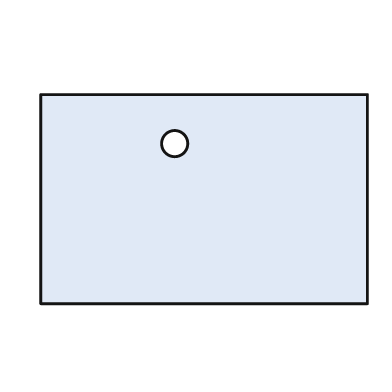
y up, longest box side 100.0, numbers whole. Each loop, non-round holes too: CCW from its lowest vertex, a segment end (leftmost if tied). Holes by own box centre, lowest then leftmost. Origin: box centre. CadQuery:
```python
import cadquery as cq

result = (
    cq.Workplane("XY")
    .moveTo(-50.0, -32.0)
    .lineTo(50.0, -32.0)
    .lineTo(50.0, 32.0)
    .lineTo(-50.0, 32.0)
    .close()
    .moveTo(-9.0, 17.0)
    .circle(4.0)
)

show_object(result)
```